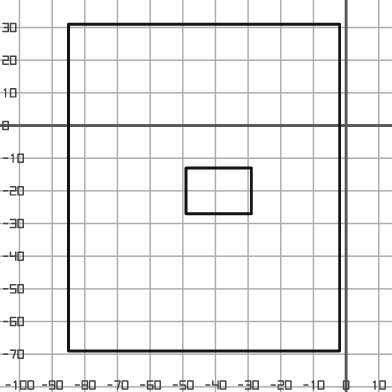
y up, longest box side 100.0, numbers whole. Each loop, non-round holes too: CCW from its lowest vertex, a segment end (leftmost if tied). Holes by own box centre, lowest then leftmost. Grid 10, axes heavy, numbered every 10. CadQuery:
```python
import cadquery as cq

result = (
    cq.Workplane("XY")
    .moveTo(-85.0, -69.0)
    .lineTo(-2.0, -69.0)
    .lineTo(-2.0, 31.0)
    .lineTo(-85.0, 31.0)
    .close()
    .moveTo(-49.0, -27.0)
    .lineTo(-29.0, -27.0)
    .lineTo(-29.0, -13.0)
    .lineTo(-49.0, -13.0)
    .close()
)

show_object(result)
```